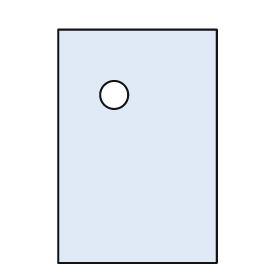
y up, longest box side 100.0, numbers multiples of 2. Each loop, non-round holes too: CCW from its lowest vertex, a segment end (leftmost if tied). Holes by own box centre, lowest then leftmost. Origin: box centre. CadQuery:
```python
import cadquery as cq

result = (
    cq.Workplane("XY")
    .moveTo(-34.0, -50.0)
    .lineTo(34.0, -50.0)
    .lineTo(34.0, 50.0)
    .lineTo(-34.0, 50.0)
    .close()
    .moveTo(-10.0, 22.0)
    .circle(6.0)
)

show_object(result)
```